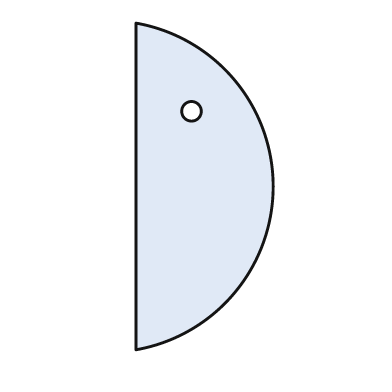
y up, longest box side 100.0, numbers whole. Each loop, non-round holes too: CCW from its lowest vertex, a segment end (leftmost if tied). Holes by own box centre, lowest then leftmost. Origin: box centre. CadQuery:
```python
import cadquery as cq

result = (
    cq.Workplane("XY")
    .moveTo(-21.0, -50.0)
    .threePointArc((21.0, 0.0), (-21.0, 50.0))
    .close()
    .moveTo(-4.0, 23.0)
    .circle(3.0)
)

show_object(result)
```